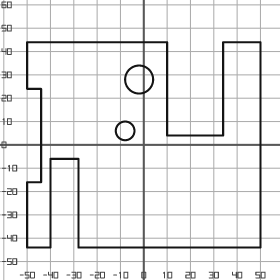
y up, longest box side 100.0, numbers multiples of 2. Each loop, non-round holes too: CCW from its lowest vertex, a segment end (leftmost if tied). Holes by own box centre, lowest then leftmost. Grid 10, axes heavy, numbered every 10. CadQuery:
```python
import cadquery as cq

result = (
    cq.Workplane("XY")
    .moveTo(-50.0, -44.0)
    .lineTo(-40.0, -44.0)
    .lineTo(-40.0, -6.0)
    .lineTo(-28.0, -6.0)
    .lineTo(-28.0, -44.0)
    .lineTo(50.0, -44.0)
    .lineTo(50.0, 44.0)
    .lineTo(34.0, 44.0)
    .lineTo(34.0, 4.0)
    .lineTo(10.0, 4.0)
    .lineTo(10.0, 44.0)
    .lineTo(-50.0, 44.0)
    .lineTo(-50.0, 24.0)
    .lineTo(-44.0, 24.0)
    .lineTo(-44.0, -16.0)
    .lineTo(-50.0, -16.0)
    .close()
    .moveTo(-8.0, 6.0)
    .circle(4.0)
    .moveTo(-2.0, 28.0)
    .circle(6.0)
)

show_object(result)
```